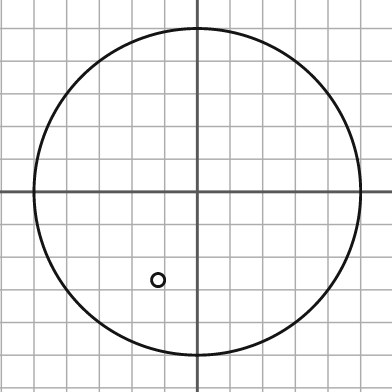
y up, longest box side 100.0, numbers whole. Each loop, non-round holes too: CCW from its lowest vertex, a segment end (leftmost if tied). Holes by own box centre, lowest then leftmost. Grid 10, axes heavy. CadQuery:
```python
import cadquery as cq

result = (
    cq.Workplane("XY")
    .moveTo(0.0, 0.0)
    .circle(50.0)
    .moveTo(-12.0, -27.0)
    .circle(2.0)
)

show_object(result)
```